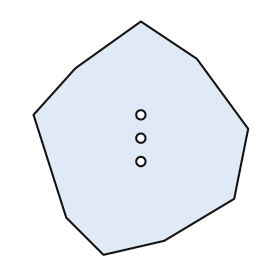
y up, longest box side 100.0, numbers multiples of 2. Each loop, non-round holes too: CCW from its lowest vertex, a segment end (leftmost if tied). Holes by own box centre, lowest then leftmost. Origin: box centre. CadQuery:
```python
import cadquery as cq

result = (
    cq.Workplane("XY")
    .moveTo(-16.0, -50.0)
    .lineTo(10.0, -44.0)
    .lineTo(40.0, -26.0)
    .lineTo(46.0, 4.0)
    .lineTo(24.0, 34.0)
    .lineTo(0.0, 50.0)
    .lineTo(-28.0, 30.0)
    .lineTo(-46.0, 10.0)
    .lineTo(-32.0, -34.0)
    .close()
    .moveTo(0.0, -10.0)
    .circle(2.0)
    .moveTo(0.0, 0.0)
    .circle(2.0)
    .moveTo(0.0, 10.0)
    .circle(2.0)
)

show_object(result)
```